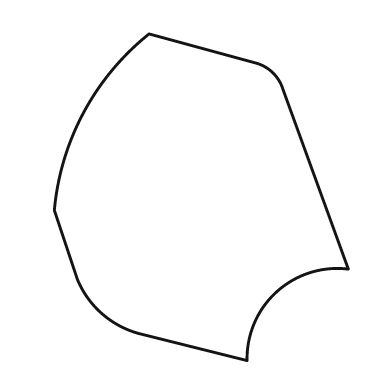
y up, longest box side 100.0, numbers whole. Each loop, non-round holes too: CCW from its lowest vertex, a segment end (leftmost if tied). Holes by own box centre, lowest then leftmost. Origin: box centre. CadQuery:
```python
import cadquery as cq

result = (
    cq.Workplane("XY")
    .moveTo(14.0, -50.0)
    .threePointArc((23.0, -29.0), (45.0, -22.0))
    .lineTo(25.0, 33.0)
    .threePointArc((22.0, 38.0), (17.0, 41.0))
    .lineTo(-16.0, 50.0)
    .threePointArc((-36.0, 26.0), (-45.0, -4.0))
    .lineTo(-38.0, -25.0)
    .threePointArc((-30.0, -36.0), (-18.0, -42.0))
    .close()
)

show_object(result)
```